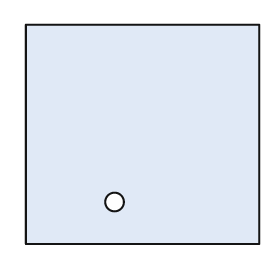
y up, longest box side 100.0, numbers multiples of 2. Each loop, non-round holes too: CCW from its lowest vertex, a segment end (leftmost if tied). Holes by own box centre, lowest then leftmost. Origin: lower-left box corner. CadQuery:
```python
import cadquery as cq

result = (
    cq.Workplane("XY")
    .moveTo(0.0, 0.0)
    .lineTo(100.0, 0.0)
    .lineTo(100.0, 94.0)
    .lineTo(0.0, 94.0)
    .close()
    .moveTo(38.0, 18.0)
    .circle(4.0)
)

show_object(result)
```